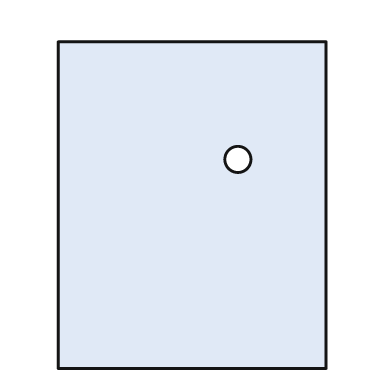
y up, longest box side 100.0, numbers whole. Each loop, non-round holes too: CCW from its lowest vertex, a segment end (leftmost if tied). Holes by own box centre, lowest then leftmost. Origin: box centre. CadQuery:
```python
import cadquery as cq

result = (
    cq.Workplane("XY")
    .moveTo(-41.0, -50.0)
    .lineTo(41.0, -50.0)
    .lineTo(41.0, 50.0)
    .lineTo(-41.0, 50.0)
    .close()
    .moveTo(14.0, 14.0)
    .circle(4.0)
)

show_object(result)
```